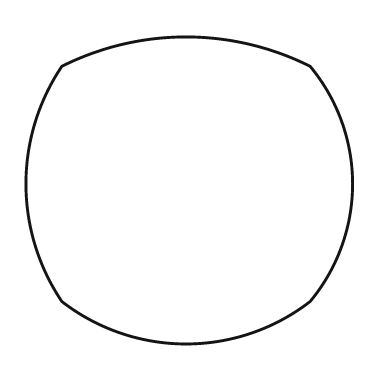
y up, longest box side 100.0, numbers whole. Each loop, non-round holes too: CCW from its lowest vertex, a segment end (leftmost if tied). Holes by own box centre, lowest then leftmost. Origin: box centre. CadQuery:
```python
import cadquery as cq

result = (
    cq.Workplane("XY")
    .moveTo(-39.0, -34.0)
    .threePointArc((-1.0, -47.0), (37.0, -34.0))
    .threePointArc((50.0, 2.0), (37.0, 38.0))
    .threePointArc((-1.0, 47.0), (-39.0, 38.0))
    .threePointArc((-50.0, 2.0), (-39.0, -34.0))
    .close()
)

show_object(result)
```